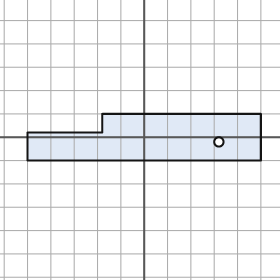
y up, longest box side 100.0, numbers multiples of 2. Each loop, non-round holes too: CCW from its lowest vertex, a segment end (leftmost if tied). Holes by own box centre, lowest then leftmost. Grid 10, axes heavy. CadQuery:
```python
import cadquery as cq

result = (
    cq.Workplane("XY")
    .moveTo(-50.0, -10.0)
    .lineTo(50.0, -10.0)
    .lineTo(50.0, 10.0)
    .lineTo(-18.0, 10.0)
    .lineTo(-18.0, 2.0)
    .lineTo(-50.0, 2.0)
    .close()
    .moveTo(32.0, -2.0)
    .circle(2.0)
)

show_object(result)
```